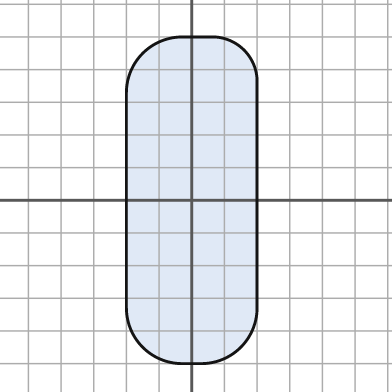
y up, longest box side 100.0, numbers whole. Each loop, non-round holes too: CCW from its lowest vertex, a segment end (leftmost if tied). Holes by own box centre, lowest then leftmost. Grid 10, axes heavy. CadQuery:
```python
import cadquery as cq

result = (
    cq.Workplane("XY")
    .moveTo(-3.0, -50.0)
    .lineTo(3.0, -50.0)
    .threePointArc((15.0, -45.0), (20.0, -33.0))
    .lineTo(20.0, 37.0)
    .threePointArc((16.0, 46.0), (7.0, 50.0))
    .lineTo(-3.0, 50.0)
    .threePointArc((-15.0, 45.0), (-20.0, 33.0))
    .lineTo(-20.0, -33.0)
    .threePointArc((-15.0, -45.0), (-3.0, -50.0))
    .close()
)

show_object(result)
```